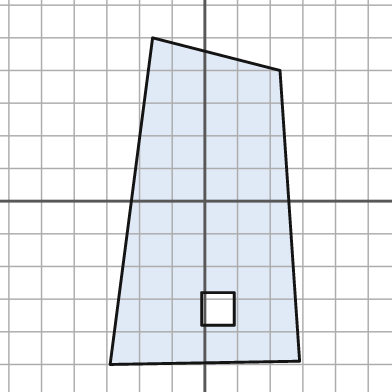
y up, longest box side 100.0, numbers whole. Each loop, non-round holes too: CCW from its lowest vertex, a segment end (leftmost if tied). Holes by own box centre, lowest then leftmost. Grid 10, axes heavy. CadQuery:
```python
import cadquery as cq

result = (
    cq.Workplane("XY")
    .moveTo(-29.0, -50.0)
    .lineTo(29.0, -49.0)
    .lineTo(23.0, 40.0)
    .lineTo(-16.0, 50.0)
    .close()
    .moveTo(-1.0, -38.0)
    .lineTo(9.0, -38.0)
    .lineTo(9.0, -28.0)
    .lineTo(-1.0, -28.0)
    .close()
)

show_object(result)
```